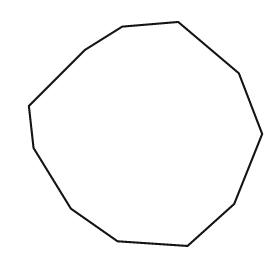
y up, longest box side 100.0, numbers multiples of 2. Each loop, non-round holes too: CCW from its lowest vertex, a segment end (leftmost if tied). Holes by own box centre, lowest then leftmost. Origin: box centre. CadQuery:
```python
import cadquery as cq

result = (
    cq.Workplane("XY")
    .moveTo(18.0, -48.0)
    .lineTo(38.0, -30.0)
    .lineTo(50.0, 0.0)
    .lineTo(40.0, 26.0)
    .lineTo(14.0, 48.0)
    .lineTo(-10.0, 46.0)
    .lineTo(-26.0, 36.0)
    .lineTo(-50.0, 12.0)
    .lineTo(-48.0, -6.0)
    .lineTo(-32.0, -32.0)
    .lineTo(-12.0, -46.0)
    .close()
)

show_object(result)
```